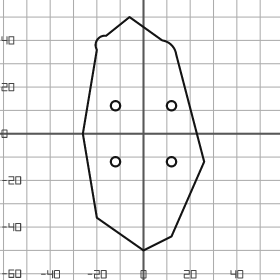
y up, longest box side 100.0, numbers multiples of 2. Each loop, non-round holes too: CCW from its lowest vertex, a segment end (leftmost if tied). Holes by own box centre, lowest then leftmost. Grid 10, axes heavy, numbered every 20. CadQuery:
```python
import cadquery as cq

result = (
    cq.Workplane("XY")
    .moveTo(0.0, -50.0)
    .lineTo(12.0, -44.0)
    .lineTo(26.0, -12.0)
    .lineTo(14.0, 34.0)
    .threePointArc((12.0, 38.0), (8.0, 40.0))
    .lineTo(-6.0, 50.0)
    .lineTo(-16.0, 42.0)
    .threePointArc((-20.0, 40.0), (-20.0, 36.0))
    .lineTo(-26.0, 0.0)
    .lineTo(-20.0, -36.0)
    .close()
    .moveTo(-12.0, -12.0)
    .circle(2.0)
    .moveTo(12.0, -12.0)
    .circle(2.0)
    .moveTo(-12.0, 12.0)
    .circle(2.0)
    .moveTo(12.0, 12.0)
    .circle(2.0)
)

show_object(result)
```